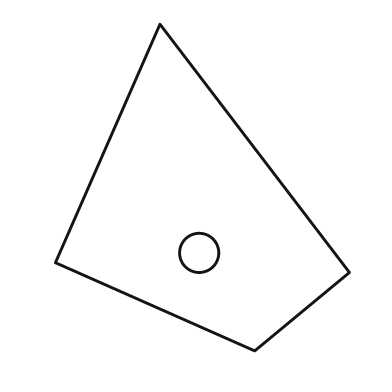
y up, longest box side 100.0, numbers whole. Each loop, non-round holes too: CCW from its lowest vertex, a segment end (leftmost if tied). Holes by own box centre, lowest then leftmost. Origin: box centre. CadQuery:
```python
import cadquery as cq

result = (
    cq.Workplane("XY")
    .moveTo(16.0, -50.0)
    .lineTo(45.0, -26.0)
    .lineTo(-13.0, 50.0)
    .lineTo(-45.0, -23.0)
    .close()
    .moveTo(-1.0, -20.0)
    .circle(6.0)
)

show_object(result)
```